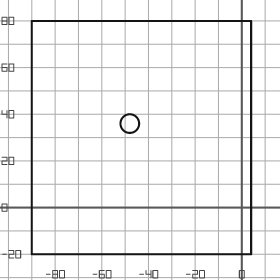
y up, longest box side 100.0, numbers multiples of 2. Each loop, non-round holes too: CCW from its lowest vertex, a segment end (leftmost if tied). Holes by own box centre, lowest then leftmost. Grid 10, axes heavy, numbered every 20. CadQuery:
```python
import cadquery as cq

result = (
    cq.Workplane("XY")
    .moveTo(-90.0, -20.0)
    .lineTo(4.0, -20.0)
    .lineTo(4.0, 80.0)
    .lineTo(-90.0, 80.0)
    .close()
    .moveTo(-48.0, 36.0)
    .circle(4.0)
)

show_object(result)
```